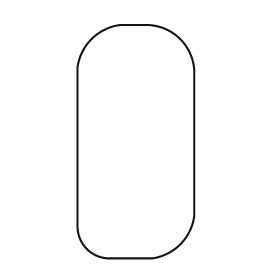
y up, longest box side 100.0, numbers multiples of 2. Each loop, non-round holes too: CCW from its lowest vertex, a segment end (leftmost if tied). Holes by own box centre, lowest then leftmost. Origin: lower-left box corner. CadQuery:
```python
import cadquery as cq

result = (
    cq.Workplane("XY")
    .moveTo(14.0, 0.0)
    .lineTo(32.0, 0.0)
    .threePointArc((44.0, 6.0), (50.0, 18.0))
    .lineTo(50.0, 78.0)
    .threePointArc((44.0, 94.0), (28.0, 100.0))
    .lineTo(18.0, 100.0)
    .threePointArc((6.0, 94.0), (0.0, 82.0))
    .lineTo(0.0, 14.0)
    .threePointArc((4.0, 4.0), (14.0, 0.0))
    .close()
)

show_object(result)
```